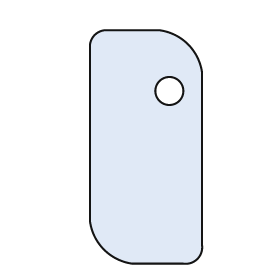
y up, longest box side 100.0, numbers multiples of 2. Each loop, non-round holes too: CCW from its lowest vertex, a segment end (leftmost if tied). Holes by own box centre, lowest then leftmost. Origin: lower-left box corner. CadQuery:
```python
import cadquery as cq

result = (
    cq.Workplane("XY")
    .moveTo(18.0, 0.0)
    .lineTo(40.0, 0.0)
    .threePointArc((46.0, 2.0), (48.0, 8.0))
    .lineTo(48.0, 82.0)
    .threePointArc((42.0, 94.0), (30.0, 100.0))
    .lineTo(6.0, 100.0)
    .threePointArc((2.0, 98.0), (0.0, 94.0))
    .lineTo(0.0, 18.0)
    .threePointArc((6.0, 6.0), (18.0, 0.0))
    .close()
    .moveTo(34.0, 74.0)
    .circle(6.0)
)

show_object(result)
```